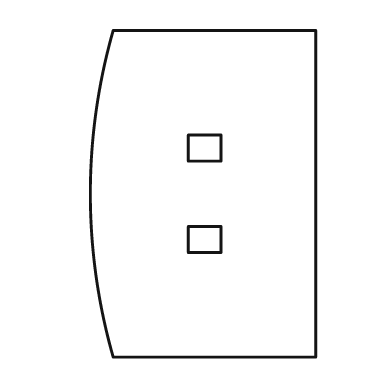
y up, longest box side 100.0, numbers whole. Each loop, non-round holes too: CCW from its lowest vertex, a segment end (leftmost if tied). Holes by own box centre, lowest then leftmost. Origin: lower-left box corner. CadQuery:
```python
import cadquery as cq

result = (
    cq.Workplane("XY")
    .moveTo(7.0, 0.0)
    .lineTo(69.0, 0.0)
    .lineTo(69.0, 100.0)
    .lineTo(7.0, 100.0)
    .threePointArc((0.0, 50.0), (7.0, 0.0))
    .close()
    .moveTo(30.0, 32.0)
    .lineTo(40.0, 32.0)
    .lineTo(40.0, 40.0)
    .lineTo(30.0, 40.0)
    .close()
    .moveTo(30.0, 60.0)
    .lineTo(40.0, 60.0)
    .lineTo(40.0, 68.0)
    .lineTo(30.0, 68.0)
    .close()
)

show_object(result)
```